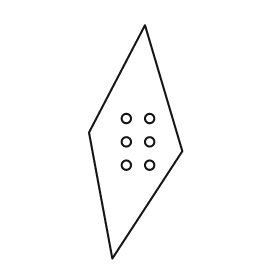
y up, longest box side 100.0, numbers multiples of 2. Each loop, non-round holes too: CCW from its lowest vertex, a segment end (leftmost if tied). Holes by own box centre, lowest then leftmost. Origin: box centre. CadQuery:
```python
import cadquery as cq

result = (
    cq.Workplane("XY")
    .moveTo(-10.0, -50.0)
    .lineTo(20.0, -4.0)
    .lineTo(4.0, 50.0)
    .lineTo(-20.0, 4.0)
    .close()
    .moveTo(-4.0, -10.0)
    .circle(2.0)
    .moveTo(6.0, -10.0)
    .circle(2.0)
    .moveTo(-4.0, 0.0)
    .circle(2.0)
    .moveTo(6.0, 0.0)
    .circle(2.0)
    .moveTo(-4.0, 10.0)
    .circle(2.0)
    .moveTo(6.0, 10.0)
    .circle(2.0)
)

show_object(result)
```